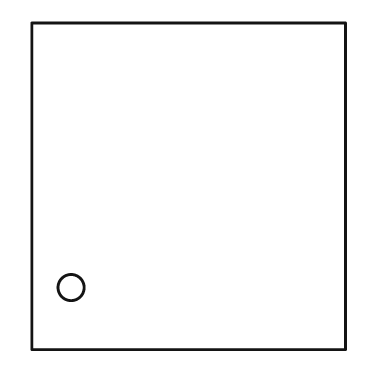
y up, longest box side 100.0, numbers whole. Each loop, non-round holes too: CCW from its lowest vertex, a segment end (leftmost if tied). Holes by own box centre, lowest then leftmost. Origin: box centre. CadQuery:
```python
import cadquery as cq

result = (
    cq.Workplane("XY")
    .moveTo(-48.0, -50.0)
    .lineTo(48.0, -50.0)
    .lineTo(48.0, 50.0)
    .lineTo(-48.0, 50.0)
    .close()
    .moveTo(-36.0, -31.0)
    .circle(4.0)
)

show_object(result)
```